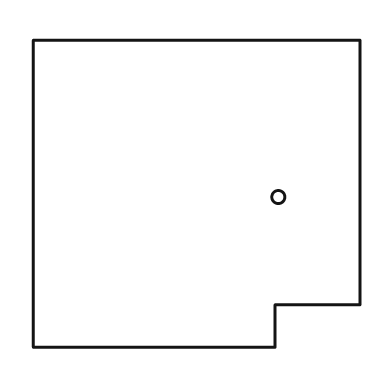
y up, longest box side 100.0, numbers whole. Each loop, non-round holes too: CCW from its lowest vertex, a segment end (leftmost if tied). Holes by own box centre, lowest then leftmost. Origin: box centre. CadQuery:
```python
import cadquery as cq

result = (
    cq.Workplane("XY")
    .moveTo(-50.0, -47.0)
    .lineTo(24.0, -47.0)
    .lineTo(24.0, -34.0)
    .lineTo(50.0, -34.0)
    .lineTo(50.0, 47.0)
    .lineTo(-50.0, 47.0)
    .close()
    .moveTo(25.0, -1.0)
    .circle(2.0)
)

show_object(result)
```